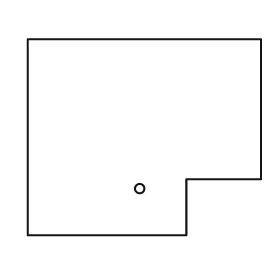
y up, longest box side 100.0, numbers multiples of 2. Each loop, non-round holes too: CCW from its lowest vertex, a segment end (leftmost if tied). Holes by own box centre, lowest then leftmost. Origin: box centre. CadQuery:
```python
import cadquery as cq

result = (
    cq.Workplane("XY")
    .moveTo(-50.0, -42.0)
    .lineTo(18.0, -42.0)
    .lineTo(18.0, -18.0)
    .lineTo(50.0, -18.0)
    .lineTo(50.0, 42.0)
    .lineTo(-50.0, 42.0)
    .close()
    .moveTo(-2.0, -22.0)
    .circle(2.0)
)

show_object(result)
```